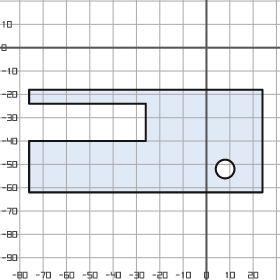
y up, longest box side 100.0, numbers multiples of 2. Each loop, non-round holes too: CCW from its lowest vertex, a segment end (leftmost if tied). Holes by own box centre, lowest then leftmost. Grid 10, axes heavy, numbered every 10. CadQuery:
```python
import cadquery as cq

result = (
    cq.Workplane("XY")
    .moveTo(-76.0, -62.0)
    .lineTo(24.0, -62.0)
    .lineTo(24.0, -18.0)
    .lineTo(-76.0, -18.0)
    .lineTo(-76.0, -24.0)
    .lineTo(-26.0, -24.0)
    .lineTo(-26.0, -40.0)
    .lineTo(-76.0, -40.0)
    .close()
    .moveTo(8.0, -52.0)
    .circle(4.0)
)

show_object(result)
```